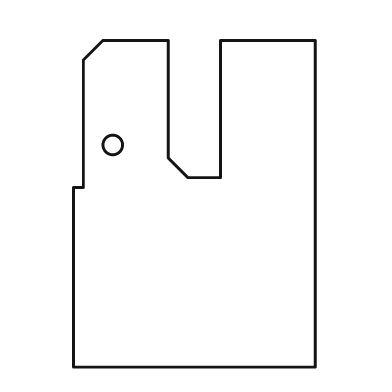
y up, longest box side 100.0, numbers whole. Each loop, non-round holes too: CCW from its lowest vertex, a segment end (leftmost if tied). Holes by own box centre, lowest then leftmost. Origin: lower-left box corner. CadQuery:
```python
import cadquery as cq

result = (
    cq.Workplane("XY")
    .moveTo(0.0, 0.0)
    .lineTo(74.0, 0.0)
    .lineTo(74.0, 100.0)
    .lineTo(45.0, 100.0)
    .lineTo(45.0, 58.0)
    .lineTo(35.0, 58.0)
    .lineTo(29.0, 64.0)
    .lineTo(29.0, 100.0)
    .lineTo(9.0, 100.0)
    .lineTo(3.0, 94.0)
    .lineTo(3.0, 55.0)
    .lineTo(0.0, 55.0)
    .close()
    .moveTo(12.0, 68.0)
    .circle(3.0)
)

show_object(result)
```